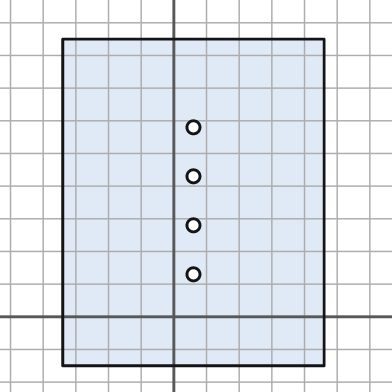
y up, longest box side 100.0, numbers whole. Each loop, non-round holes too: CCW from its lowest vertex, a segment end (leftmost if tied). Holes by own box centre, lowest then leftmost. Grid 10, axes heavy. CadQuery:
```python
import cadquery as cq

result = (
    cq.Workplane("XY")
    .moveTo(-34.0, -15.0)
    .lineTo(46.0, -15.0)
    .lineTo(46.0, 85.0)
    .lineTo(-34.0, 85.0)
    .close()
    .moveTo(6.0, 13.0)
    .circle(2.0)
    .moveTo(6.0, 28.0)
    .circle(2.0)
    .moveTo(6.0, 43.0)
    .circle(2.0)
    .moveTo(6.0, 58.0)
    .circle(2.0)
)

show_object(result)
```